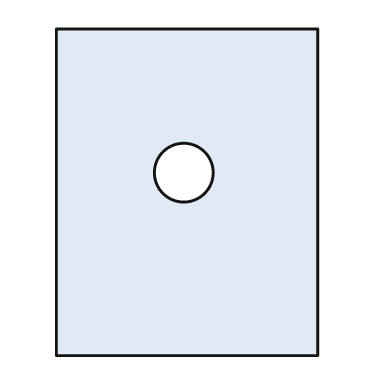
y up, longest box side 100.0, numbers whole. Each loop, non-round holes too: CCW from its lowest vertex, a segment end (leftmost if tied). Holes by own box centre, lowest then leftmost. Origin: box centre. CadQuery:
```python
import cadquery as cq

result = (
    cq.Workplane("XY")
    .moveTo(-40.0, -50.0)
    .lineTo(40.0, -50.0)
    .lineTo(40.0, 50.0)
    .lineTo(-40.0, 50.0)
    .close()
    .moveTo(-1.0, 6.0)
    .circle(9.0)
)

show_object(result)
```